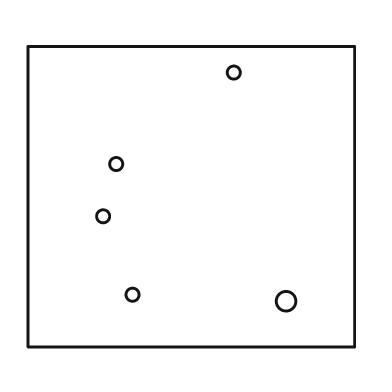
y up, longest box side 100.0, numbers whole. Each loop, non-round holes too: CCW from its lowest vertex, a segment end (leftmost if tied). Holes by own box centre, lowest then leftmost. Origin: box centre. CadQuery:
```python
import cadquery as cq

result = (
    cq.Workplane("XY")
    .moveTo(-50.0, -46.0)
    .lineTo(50.0, -46.0)
    .lineTo(50.0, 46.0)
    .lineTo(-50.0, 46.0)
    .close()
    .moveTo(29.0, -32.0)
    .circle(3.0)
    .moveTo(-18.0, -30.0)
    .circle(2.0)
    .moveTo(-27.0, -6.0)
    .circle(2.0)
    .moveTo(-23.0, 10.0)
    .circle(2.0)
    .moveTo(13.0, 38.0)
    .circle(2.0)
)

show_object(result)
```